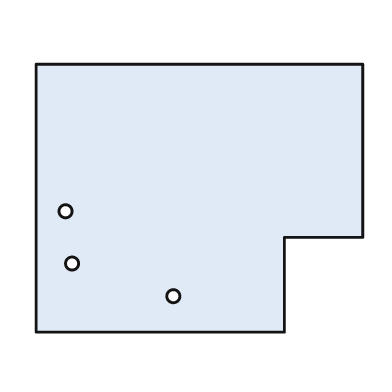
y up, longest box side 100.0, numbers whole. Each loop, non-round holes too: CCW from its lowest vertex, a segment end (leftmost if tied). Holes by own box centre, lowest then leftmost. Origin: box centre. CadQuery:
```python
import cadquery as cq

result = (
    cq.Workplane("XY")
    .moveTo(-50.0, -41.0)
    .lineTo(26.0, -41.0)
    .lineTo(26.0, -12.0)
    .lineTo(50.0, -12.0)
    .lineTo(50.0, 41.0)
    .lineTo(-50.0, 41.0)
    .close()
    .moveTo(-8.0, -30.0)
    .circle(2.0)
    .moveTo(-39.0, -20.0)
    .circle(2.0)
    .moveTo(-41.0, -4.0)
    .circle(2.0)
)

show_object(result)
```